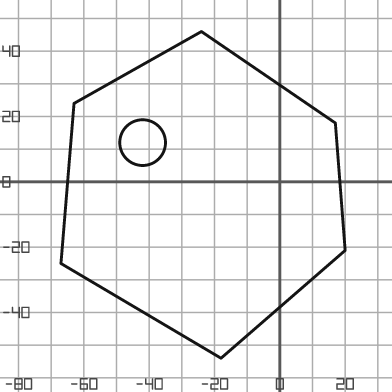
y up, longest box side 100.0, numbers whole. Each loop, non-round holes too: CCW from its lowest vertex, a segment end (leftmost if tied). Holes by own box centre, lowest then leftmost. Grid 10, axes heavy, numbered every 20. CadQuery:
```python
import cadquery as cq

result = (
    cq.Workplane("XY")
    .moveTo(-18.0, -54.0)
    .lineTo(20.0, -21.0)
    .lineTo(17.0, 18.0)
    .lineTo(-24.0, 46.0)
    .lineTo(-63.0, 24.0)
    .lineTo(-67.0, -25.0)
    .close()
    .moveTo(-42.0, 12.0)
    .circle(7.0)
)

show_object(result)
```